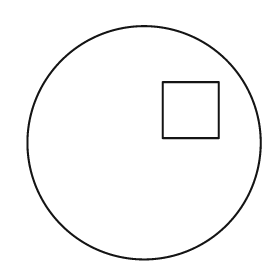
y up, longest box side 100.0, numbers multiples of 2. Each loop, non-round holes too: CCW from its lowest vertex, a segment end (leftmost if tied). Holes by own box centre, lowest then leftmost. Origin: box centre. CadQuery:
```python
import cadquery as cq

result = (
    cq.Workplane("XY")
    .moveTo(0.0, 0.0)
    .circle(50.0)
    .moveTo(8.0, 2.0)
    .lineTo(32.0, 2.0)
    .lineTo(32.0, 26.0)
    .lineTo(8.0, 26.0)
    .close()
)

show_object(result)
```